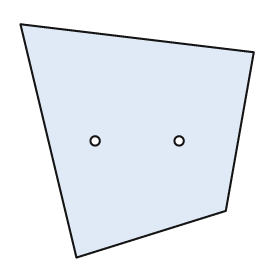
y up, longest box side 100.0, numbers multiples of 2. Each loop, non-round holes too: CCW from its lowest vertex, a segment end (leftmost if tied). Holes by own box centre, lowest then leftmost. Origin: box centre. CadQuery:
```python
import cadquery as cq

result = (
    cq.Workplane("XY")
    .moveTo(-26.0, -50.0)
    .lineTo(38.0, -30.0)
    .lineTo(50.0, 38.0)
    .lineTo(-50.0, 50.0)
    .close()
    .moveTo(-18.0, 0.0)
    .circle(2.0)
    .moveTo(18.0, 0.0)
    .circle(2.0)
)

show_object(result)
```